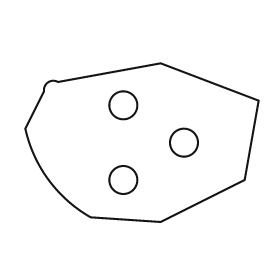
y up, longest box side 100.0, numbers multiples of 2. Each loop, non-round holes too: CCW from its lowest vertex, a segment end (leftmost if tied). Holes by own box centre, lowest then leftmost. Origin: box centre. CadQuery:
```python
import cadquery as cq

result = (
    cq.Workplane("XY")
    .moveTo(8.0, -34.0)
    .lineTo(44.0, -16.0)
    .lineTo(50.0, 18.0)
    .lineTo(8.0, 34.0)
    .lineTo(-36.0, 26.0)
    .threePointArc((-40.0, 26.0), (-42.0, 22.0))
    .lineTo(-50.0, 6.0)
    .threePointArc((-40.0, -16.0), (-22.0, -32.0))
    .close()
    .moveTo(-8.0, -16.0)
    .circle(6.0)
    .moveTo(18.0, 0.0)
    .circle(6.0)
    .moveTo(-8.0, 16.0)
    .circle(6.0)
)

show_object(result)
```